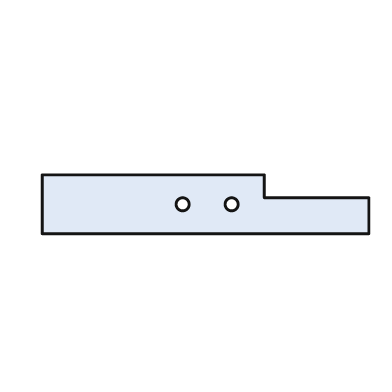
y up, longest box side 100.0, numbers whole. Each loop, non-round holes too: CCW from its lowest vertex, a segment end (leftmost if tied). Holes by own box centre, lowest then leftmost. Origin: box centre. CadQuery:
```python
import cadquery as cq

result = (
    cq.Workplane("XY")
    .moveTo(-50.0, -9.0)
    .lineTo(50.0, -9.0)
    .lineTo(50.0, 2.0)
    .lineTo(18.0, 2.0)
    .lineTo(18.0, 9.0)
    .lineTo(-50.0, 9.0)
    .close()
    .moveTo(-7.0, 0.0)
    .circle(2.0)
    .moveTo(8.0, 0.0)
    .circle(2.0)
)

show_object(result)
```